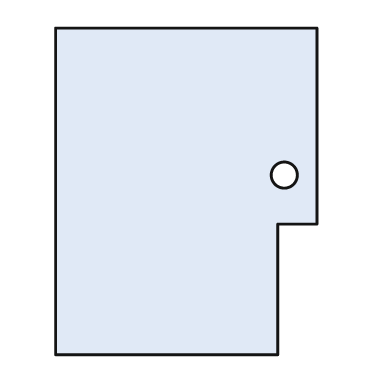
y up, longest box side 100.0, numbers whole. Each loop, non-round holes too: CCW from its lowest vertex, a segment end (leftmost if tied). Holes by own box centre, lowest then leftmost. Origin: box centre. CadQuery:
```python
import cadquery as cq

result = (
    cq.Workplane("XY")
    .moveTo(-40.0, -50.0)
    .lineTo(28.0, -50.0)
    .lineTo(28.0, -10.0)
    .lineTo(40.0, -10.0)
    .lineTo(40.0, 50.0)
    .lineTo(-40.0, 50.0)
    .close()
    .moveTo(30.0, 5.0)
    .circle(4.0)
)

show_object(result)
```